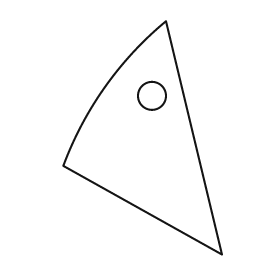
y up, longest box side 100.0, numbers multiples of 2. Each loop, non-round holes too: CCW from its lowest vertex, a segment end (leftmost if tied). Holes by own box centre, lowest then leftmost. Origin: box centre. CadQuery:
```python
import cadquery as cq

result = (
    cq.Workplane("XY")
    .moveTo(34.0, -50.0)
    .lineTo(10.0, 50.0)
    .threePointArc((-16.0, 22.0), (-34.0, -12.0))
    .close()
    .moveTo(4.0, 18.0)
    .circle(6.0)
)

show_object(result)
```